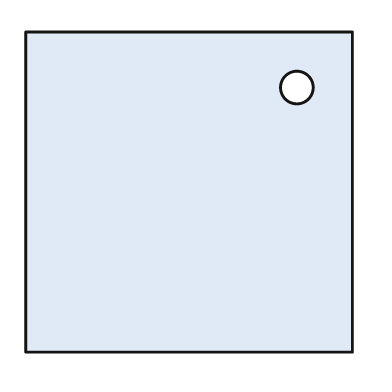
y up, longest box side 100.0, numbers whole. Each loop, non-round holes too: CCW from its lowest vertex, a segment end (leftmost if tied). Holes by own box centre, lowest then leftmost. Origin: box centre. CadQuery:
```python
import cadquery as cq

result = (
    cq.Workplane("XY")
    .moveTo(-50.0, -49.0)
    .lineTo(50.0, -49.0)
    .lineTo(50.0, 49.0)
    .lineTo(-50.0, 49.0)
    .close()
    .moveTo(33.0, 32.0)
    .circle(5.0)
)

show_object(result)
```